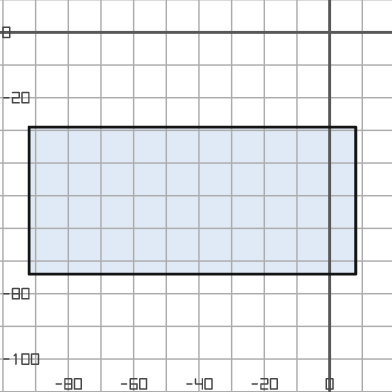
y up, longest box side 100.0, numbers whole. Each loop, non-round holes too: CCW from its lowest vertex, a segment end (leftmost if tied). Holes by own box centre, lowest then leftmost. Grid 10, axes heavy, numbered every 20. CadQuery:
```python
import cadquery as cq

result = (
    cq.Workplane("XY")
    .moveTo(-92.0, -74.0)
    .lineTo(8.0, -74.0)
    .lineTo(8.0, -29.0)
    .lineTo(-92.0, -29.0)
    .close()
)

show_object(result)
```